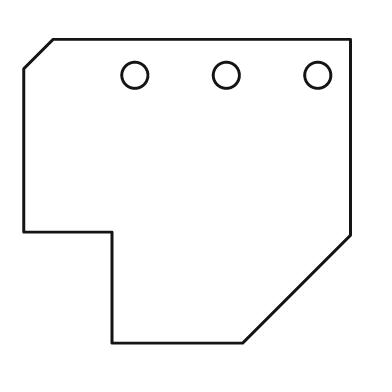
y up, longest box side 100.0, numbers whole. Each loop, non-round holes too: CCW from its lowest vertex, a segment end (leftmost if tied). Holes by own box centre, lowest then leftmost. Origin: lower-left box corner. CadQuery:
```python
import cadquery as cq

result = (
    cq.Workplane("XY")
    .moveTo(27.0, 0.0)
    .lineTo(67.0, 0.0)
    .lineTo(100.0, 33.0)
    .lineTo(100.0, 93.0)
    .lineTo(9.0, 93.0)
    .lineTo(0.0, 84.0)
    .lineTo(0.0, 34.0)
    .lineTo(27.0, 34.0)
    .close()
    .moveTo(34.0, 82.0)
    .circle(4.0)
    .moveTo(62.0, 82.0)
    .circle(4.0)
    .moveTo(90.0, 82.0)
    .circle(4.0)
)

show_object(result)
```